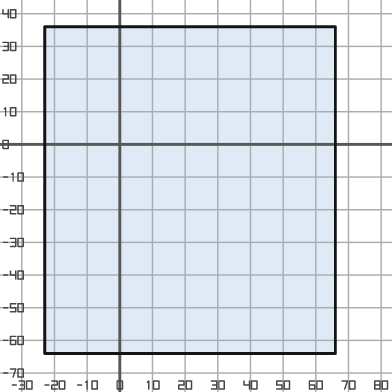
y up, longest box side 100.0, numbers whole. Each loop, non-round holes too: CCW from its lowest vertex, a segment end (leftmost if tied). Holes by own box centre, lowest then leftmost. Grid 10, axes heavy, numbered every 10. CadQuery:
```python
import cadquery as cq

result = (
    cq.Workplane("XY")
    .moveTo(-23.0, -64.0)
    .lineTo(66.0, -64.0)
    .lineTo(66.0, 36.0)
    .lineTo(-23.0, 36.0)
    .close()
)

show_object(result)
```